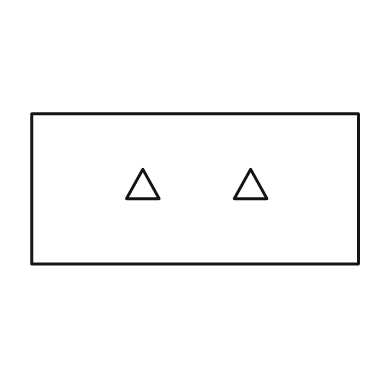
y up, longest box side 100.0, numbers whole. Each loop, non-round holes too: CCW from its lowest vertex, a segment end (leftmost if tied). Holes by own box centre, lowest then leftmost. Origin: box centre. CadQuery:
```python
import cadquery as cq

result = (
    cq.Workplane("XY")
    .moveTo(-50.0, -23.0)
    .lineTo(50.0, -23.0)
    .lineTo(50.0, 23.0)
    .lineTo(-50.0, 23.0)
    .close()
    .moveTo(-21.0, -3.0)
    .lineTo(-11.0, -3.0)
    .lineTo(-16.0, 6.0)
    .close()
    .moveTo(12.0, -3.0)
    .lineTo(22.0, -3.0)
    .lineTo(17.0, 6.0)
    .close()
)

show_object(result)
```